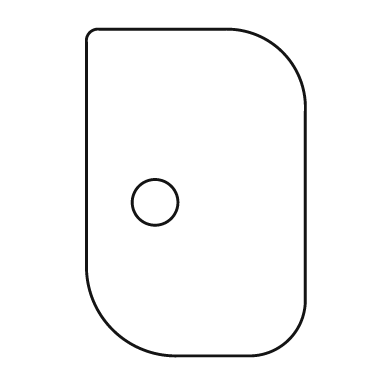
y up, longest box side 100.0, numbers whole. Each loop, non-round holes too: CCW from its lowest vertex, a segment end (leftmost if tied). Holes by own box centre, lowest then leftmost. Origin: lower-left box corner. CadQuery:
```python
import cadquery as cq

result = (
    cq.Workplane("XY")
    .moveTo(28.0, 0.0)
    .lineTo(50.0, 0.0)
    .threePointArc((62.0, 5.0), (67.0, 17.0))
    .lineTo(67.0, 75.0)
    .threePointArc((60.0, 93.0), (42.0, 100.0))
    .lineTo(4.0, 100.0)
    .threePointArc((1.0, 99.0), (0.0, 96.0))
    .lineTo(0.0, 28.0)
    .threePointArc((8.0, 8.0), (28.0, 0.0))
    .close()
    .moveTo(21.0, 47.0)
    .circle(7.0)
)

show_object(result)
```